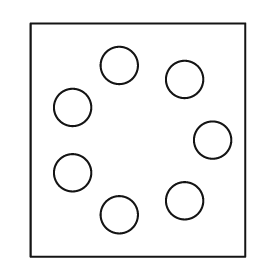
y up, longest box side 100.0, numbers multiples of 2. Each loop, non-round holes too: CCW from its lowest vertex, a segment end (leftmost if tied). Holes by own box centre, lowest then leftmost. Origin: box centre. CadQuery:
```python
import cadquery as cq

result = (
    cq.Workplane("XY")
    .moveTo(-46.0, -50.0)
    .lineTo(46.0, -50.0)
    .lineTo(46.0, 50.0)
    .lineTo(-46.0, 50.0)
    .close()
    .moveTo(-8.0, -32.0)
    .circle(8.0)
    .moveTo(20.0, -26.0)
    .circle(8.0)
    .moveTo(-28.0, -14.0)
    .circle(8.0)
    .moveTo(32.0, 0.0)
    .circle(8.0)
    .moveTo(-28.0, 14.0)
    .circle(8.0)
    .moveTo(20.0, 26.0)
    .circle(8.0)
    .moveTo(-8.0, 32.0)
    .circle(8.0)
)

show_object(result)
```